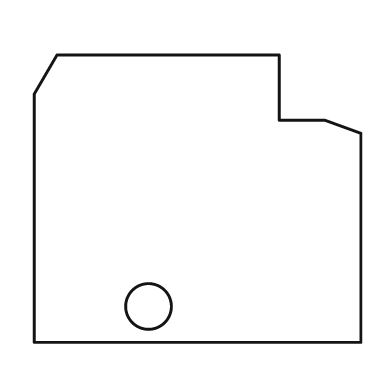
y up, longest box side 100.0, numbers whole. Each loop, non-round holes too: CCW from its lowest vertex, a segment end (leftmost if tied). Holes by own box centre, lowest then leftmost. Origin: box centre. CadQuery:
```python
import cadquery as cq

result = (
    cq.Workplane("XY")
    .moveTo(-50.0, -44.0)
    .lineTo(50.0, -44.0)
    .lineTo(50.0, 20.0)
    .lineTo(39.0, 24.0)
    .lineTo(25.0, 24.0)
    .lineTo(25.0, 44.0)
    .lineTo(-43.0, 44.0)
    .lineTo(-50.0, 32.0)
    .close()
    .moveTo(-15.0, -33.0)
    .circle(7.0)
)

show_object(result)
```